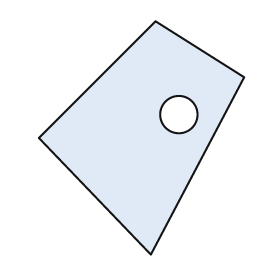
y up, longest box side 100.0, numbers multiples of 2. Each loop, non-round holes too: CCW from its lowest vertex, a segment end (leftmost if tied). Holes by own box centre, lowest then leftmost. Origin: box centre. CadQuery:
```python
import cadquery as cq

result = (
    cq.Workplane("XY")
    .moveTo(4.0, -50.0)
    .lineTo(44.0, 26.0)
    .lineTo(6.0, 50.0)
    .lineTo(-44.0, 0.0)
    .close()
    .moveTo(16.0, 10.0)
    .circle(8.0)
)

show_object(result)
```